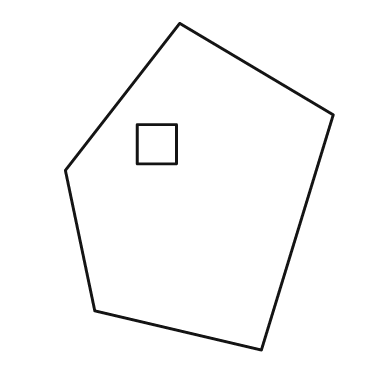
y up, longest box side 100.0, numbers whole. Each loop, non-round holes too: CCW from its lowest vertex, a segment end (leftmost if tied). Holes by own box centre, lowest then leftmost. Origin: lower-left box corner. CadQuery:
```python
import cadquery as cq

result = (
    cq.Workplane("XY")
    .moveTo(60.0, 0.0)
    .lineTo(82.0, 72.0)
    .lineTo(35.0, 100.0)
    .lineTo(0.0, 55.0)
    .lineTo(9.0, 12.0)
    .close()
    .moveTo(22.0, 57.0)
    .lineTo(34.0, 57.0)
    .lineTo(34.0, 69.0)
    .lineTo(22.0, 69.0)
    .close()
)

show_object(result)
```